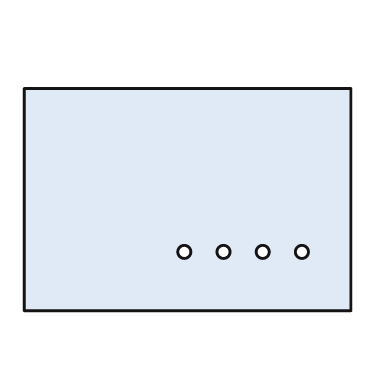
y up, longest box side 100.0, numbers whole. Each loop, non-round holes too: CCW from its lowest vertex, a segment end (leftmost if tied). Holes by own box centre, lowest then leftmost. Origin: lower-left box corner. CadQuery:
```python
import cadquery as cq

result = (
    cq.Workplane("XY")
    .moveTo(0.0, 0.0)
    .lineTo(100.0, 0.0)
    .lineTo(100.0, 68.0)
    .lineTo(0.0, 68.0)
    .close()
    .moveTo(49.0, 18.0)
    .circle(2.0)
    .moveTo(61.0, 18.0)
    .circle(2.0)
    .moveTo(73.0, 18.0)
    .circle(2.0)
    .moveTo(85.0, 18.0)
    .circle(2.0)
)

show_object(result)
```